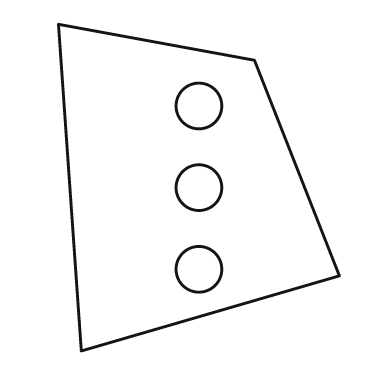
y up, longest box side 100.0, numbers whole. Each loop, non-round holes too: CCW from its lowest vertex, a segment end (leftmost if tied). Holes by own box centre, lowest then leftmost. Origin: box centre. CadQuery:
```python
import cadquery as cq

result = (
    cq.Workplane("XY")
    .moveTo(-36.0, -50.0)
    .lineTo(43.0, -27.0)
    .lineTo(17.0, 39.0)
    .lineTo(-43.0, 50.0)
    .close()
    .moveTo(0.0, -25.0)
    .circle(7.0)
    .moveTo(0.0, 0.0)
    .circle(7.0)
    .moveTo(0.0, 25.0)
    .circle(7.0)
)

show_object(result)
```